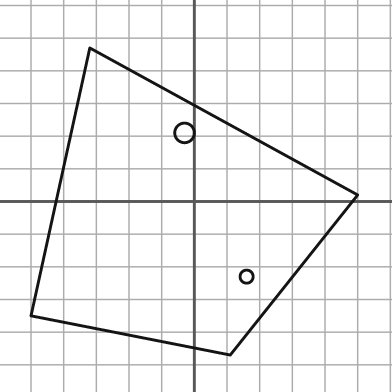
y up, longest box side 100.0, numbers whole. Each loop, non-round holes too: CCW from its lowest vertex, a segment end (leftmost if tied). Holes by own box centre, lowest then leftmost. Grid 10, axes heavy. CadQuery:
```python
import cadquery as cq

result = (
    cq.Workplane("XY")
    .moveTo(11.0, -47.0)
    .lineTo(50.0, 2.0)
    .lineTo(-32.0, 47.0)
    .lineTo(-50.0, -35.0)
    .close()
    .moveTo(16.0, -23.0)
    .circle(2.0)
    .moveTo(-3.0, 21.0)
    .circle(3.0)
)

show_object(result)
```